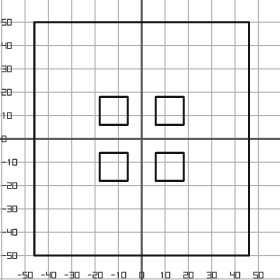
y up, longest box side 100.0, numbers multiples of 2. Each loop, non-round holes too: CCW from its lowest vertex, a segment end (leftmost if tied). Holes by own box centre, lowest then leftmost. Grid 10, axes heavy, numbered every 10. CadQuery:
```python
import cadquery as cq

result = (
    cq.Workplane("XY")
    .moveTo(-46.0, -50.0)
    .lineTo(46.0, -50.0)
    .lineTo(46.0, 50.0)
    .lineTo(-46.0, 50.0)
    .close()
    .moveTo(-18.0, -18.0)
    .lineTo(-6.0, -18.0)
    .lineTo(-6.0, -6.0)
    .lineTo(-18.0, -6.0)
    .close()
    .moveTo(6.0, -18.0)
    .lineTo(18.0, -18.0)
    .lineTo(18.0, -6.0)
    .lineTo(6.0, -6.0)
    .close()
    .moveTo(-18.0, 6.0)
    .lineTo(-6.0, 6.0)
    .lineTo(-6.0, 18.0)
    .lineTo(-18.0, 18.0)
    .close()
    .moveTo(6.0, 6.0)
    .lineTo(18.0, 6.0)
    .lineTo(18.0, 18.0)
    .lineTo(6.0, 18.0)
    .close()
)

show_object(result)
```